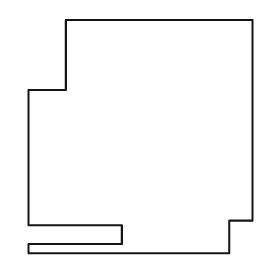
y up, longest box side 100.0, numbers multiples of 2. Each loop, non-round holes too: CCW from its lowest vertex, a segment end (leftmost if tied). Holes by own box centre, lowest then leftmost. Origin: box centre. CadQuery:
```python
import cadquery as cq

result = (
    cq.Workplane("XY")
    .moveTo(-48.0, -50.0)
    .lineTo(38.0, -50.0)
    .lineTo(38.0, -36.0)
    .lineTo(48.0, -36.0)
    .lineTo(48.0, 50.0)
    .lineTo(-32.0, 50.0)
    .lineTo(-32.0, 20.0)
    .lineTo(-48.0, 20.0)
    .lineTo(-48.0, -38.0)
    .lineTo(-8.0, -38.0)
    .lineTo(-8.0, -46.0)
    .lineTo(-48.0, -46.0)
    .close()
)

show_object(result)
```